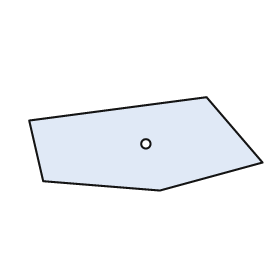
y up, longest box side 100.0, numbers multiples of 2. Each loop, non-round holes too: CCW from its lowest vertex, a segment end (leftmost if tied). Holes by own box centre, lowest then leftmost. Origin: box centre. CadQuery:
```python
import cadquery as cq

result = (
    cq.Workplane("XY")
    .moveTo(6.0, -20.0)
    .lineTo(50.0, -8.0)
    .lineTo(26.0, 20.0)
    .lineTo(-50.0, 10.0)
    .lineTo(-44.0, -16.0)
    .close()
    .moveTo(0.0, 0.0)
    .circle(2.0)
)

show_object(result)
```